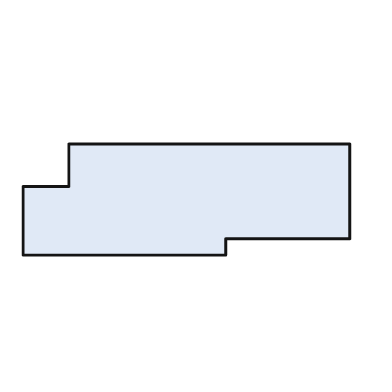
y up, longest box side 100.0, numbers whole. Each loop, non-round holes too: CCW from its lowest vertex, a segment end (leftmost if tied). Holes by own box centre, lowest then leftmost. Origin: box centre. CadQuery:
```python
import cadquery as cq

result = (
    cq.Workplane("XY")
    .moveTo(-50.0, -17.0)
    .lineTo(12.0, -17.0)
    .lineTo(12.0, -12.0)
    .lineTo(50.0, -12.0)
    .lineTo(50.0, 17.0)
    .lineTo(-36.0, 17.0)
    .lineTo(-36.0, 4.0)
    .lineTo(-50.0, 4.0)
    .close()
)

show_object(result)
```